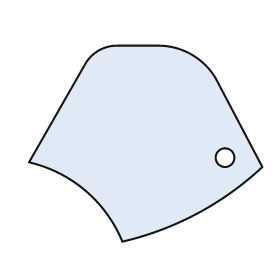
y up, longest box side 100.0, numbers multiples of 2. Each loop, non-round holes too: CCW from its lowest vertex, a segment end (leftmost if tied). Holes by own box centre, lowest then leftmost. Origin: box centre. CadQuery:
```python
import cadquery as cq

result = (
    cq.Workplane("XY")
    .moveTo(-10.0, -42.0)
    .threePointArc((22.0, -30.0), (50.0, -10.0))
    .lineTo(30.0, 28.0)
    .threePointArc((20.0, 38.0), (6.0, 42.0))
    .lineTo(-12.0, 42.0)
    .threePointArc((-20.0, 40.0), (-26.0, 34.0))
    .lineTo(-50.0, -8.0)
    .threePointArc((-26.0, -20.0), (-10.0, -42.0))
    .close()
    .moveTo(34.0, -6.0)
    .circle(4.0)
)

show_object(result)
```